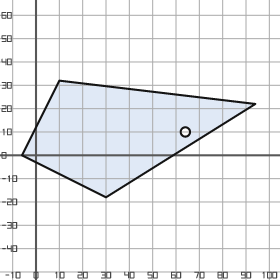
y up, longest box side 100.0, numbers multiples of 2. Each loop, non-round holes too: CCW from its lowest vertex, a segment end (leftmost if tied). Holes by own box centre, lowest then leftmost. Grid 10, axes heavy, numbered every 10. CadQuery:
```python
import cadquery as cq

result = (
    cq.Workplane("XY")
    .moveTo(30.0, -18.0)
    .lineTo(94.0, 22.0)
    .lineTo(10.0, 32.0)
    .lineTo(-6.0, 0.0)
    .close()
    .moveTo(64.0, 10.0)
    .circle(2.0)
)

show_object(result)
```